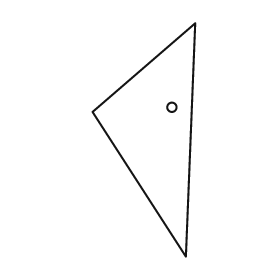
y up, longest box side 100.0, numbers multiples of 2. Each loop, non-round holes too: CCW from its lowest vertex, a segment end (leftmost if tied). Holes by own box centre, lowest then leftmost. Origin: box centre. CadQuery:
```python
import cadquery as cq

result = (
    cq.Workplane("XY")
    .moveTo(18.0, -50.0)
    .lineTo(22.0, 50.0)
    .lineTo(-22.0, 12.0)
    .close()
    .moveTo(12.0, 14.0)
    .circle(2.0)
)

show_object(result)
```